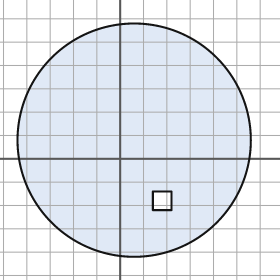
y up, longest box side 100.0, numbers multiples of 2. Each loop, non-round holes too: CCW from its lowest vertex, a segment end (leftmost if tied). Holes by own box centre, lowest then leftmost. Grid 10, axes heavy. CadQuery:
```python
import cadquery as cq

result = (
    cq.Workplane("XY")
    .moveTo(6.0, 8.0)
    .circle(50.0)
    .moveTo(14.0, -22.0)
    .lineTo(22.0, -22.0)
    .lineTo(22.0, -14.0)
    .lineTo(14.0, -14.0)
    .close()
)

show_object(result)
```